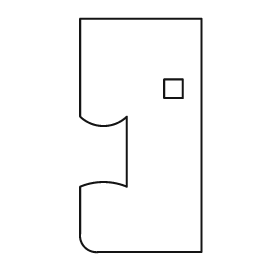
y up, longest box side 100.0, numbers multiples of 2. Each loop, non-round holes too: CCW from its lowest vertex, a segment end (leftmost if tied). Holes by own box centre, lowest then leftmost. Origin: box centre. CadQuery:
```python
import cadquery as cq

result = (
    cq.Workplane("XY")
    .moveTo(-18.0, -50.0)
    .lineTo(26.0, -50.0)
    .lineTo(26.0, 50.0)
    .lineTo(-26.0, 50.0)
    .lineTo(-26.0, 8.0)
    .threePointArc((-16.0, 4.0), (-6.0, 8.0))
    .lineTo(-6.0, -22.0)
    .threePointArc((-16.0, -20.0), (-26.0, -22.0))
    .lineTo(-26.0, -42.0)
    .threePointArc((-24.0, -48.0), (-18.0, -50.0))
    .close()
    .moveTo(10.0, 16.0)
    .lineTo(18.0, 16.0)
    .lineTo(18.0, 24.0)
    .lineTo(10.0, 24.0)
    .close()
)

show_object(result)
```